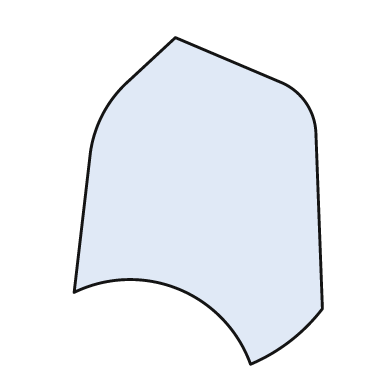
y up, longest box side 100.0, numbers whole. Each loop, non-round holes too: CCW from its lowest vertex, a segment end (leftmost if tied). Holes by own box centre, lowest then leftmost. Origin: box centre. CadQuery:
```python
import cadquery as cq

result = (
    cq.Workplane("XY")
    .moveTo(16.0, -50.0)
    .threePointArc((28.0, -43.0), (38.0, -33.0))
    .lineTo(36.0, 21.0)
    .threePointArc((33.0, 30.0), (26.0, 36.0))
    .lineTo(-7.0, 50.0)
    .lineTo(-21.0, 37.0)
    .threePointArc((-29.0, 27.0), (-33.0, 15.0))
    .lineTo(-38.0, -28.0)
    .threePointArc((-6.0, -27.0), (16.0, -50.0))
    .close()
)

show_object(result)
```